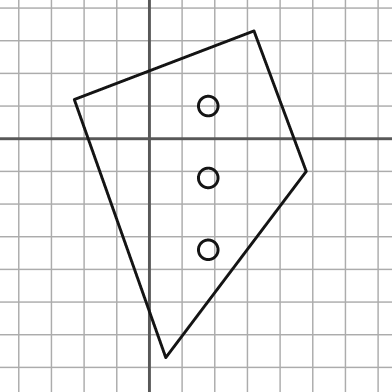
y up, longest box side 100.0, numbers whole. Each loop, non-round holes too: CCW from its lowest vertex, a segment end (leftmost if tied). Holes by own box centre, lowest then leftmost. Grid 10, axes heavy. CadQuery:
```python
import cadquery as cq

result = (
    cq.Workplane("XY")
    .moveTo(5.0, -67.0)
    .lineTo(48.0, -10.0)
    .lineTo(32.0, 33.0)
    .lineTo(-23.0, 12.0)
    .close()
    .moveTo(18.0, -34.0)
    .circle(3.0)
    .moveTo(18.0, -12.0)
    .circle(3.0)
    .moveTo(18.0, 10.0)
    .circle(3.0)
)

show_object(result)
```